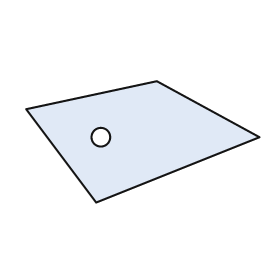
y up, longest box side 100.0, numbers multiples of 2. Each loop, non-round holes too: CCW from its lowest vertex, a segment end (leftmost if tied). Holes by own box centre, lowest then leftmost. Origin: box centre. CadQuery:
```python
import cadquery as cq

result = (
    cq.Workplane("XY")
    .moveTo(-20.0, -26.0)
    .lineTo(50.0, 2.0)
    .lineTo(6.0, 26.0)
    .lineTo(-50.0, 14.0)
    .close()
    .moveTo(-18.0, 2.0)
    .circle(4.0)
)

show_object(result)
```